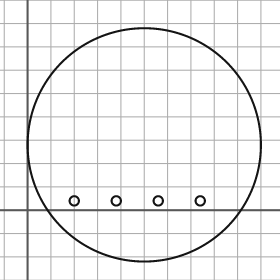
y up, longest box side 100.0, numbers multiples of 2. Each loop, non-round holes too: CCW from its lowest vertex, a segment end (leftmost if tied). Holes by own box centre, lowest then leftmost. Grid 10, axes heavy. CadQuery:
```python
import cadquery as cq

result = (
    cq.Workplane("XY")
    .moveTo(50.0, 28.0)
    .circle(50.0)
    .moveTo(20.0, 4.0)
    .circle(2.0)
    .moveTo(38.0, 4.0)
    .circle(2.0)
    .moveTo(56.0, 4.0)
    .circle(2.0)
    .moveTo(74.0, 4.0)
    .circle(2.0)
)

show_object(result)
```